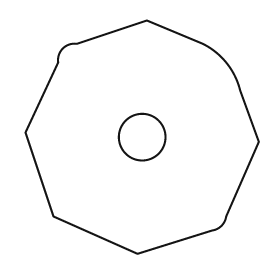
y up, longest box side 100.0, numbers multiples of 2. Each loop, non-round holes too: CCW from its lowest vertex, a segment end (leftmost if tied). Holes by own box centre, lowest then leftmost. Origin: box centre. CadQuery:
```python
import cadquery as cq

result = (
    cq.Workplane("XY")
    .moveTo(-2.0, -50.0)
    .lineTo(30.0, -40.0)
    .threePointArc((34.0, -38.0), (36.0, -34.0))
    .lineTo(50.0, -2.0)
    .lineTo(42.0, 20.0)
    .threePointArc((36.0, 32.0), (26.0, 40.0))
    .lineTo(2.0, 50.0)
    .lineTo(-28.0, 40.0)
    .threePointArc((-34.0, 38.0), (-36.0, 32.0))
    .lineTo(-50.0, 2.0)
    .lineTo(-38.0, -34.0)
    .close()
    .moveTo(0.0, 0.0)
    .circle(10.0)
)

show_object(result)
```